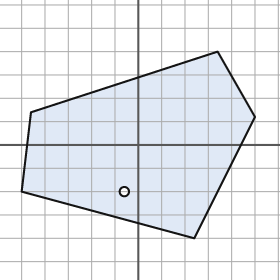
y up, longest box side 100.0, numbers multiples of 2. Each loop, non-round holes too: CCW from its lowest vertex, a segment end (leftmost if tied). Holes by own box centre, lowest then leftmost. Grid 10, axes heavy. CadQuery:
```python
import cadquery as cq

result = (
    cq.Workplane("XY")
    .moveTo(24.0, -40.0)
    .lineTo(50.0, 12.0)
    .lineTo(34.0, 40.0)
    .lineTo(-46.0, 14.0)
    .lineTo(-50.0, -20.0)
    .close()
    .moveTo(-6.0, -20.0)
    .circle(2.0)
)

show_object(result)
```